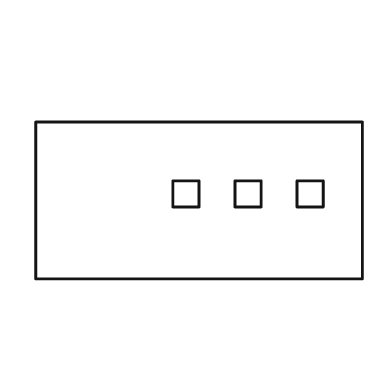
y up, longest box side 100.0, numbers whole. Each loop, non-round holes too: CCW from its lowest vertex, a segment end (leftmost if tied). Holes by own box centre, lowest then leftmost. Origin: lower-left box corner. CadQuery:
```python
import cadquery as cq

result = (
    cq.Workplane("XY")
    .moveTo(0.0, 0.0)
    .lineTo(100.0, 0.0)
    .lineTo(100.0, 48.0)
    .lineTo(0.0, 48.0)
    .close()
    .moveTo(42.0, 22.0)
    .lineTo(50.0, 22.0)
    .lineTo(50.0, 30.0)
    .lineTo(42.0, 30.0)
    .close()
    .moveTo(61.0, 22.0)
    .lineTo(69.0, 22.0)
    .lineTo(69.0, 30.0)
    .lineTo(61.0, 30.0)
    .close()
    .moveTo(80.0, 22.0)
    .lineTo(88.0, 22.0)
    .lineTo(88.0, 30.0)
    .lineTo(80.0, 30.0)
    .close()
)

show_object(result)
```